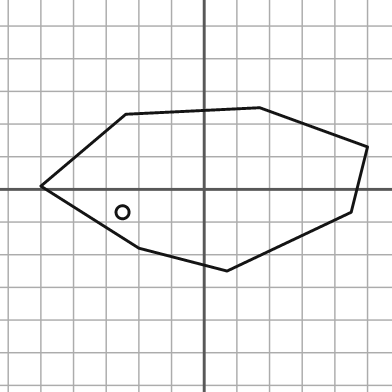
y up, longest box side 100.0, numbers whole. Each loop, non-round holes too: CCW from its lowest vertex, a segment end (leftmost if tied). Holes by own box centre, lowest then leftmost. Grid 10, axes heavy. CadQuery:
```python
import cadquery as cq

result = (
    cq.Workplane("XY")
    .moveTo(7.0, -25.0)
    .lineTo(45.0, -7.0)
    .lineTo(50.0, 13.0)
    .lineTo(17.0, 25.0)
    .lineTo(-24.0, 23.0)
    .lineTo(-50.0, 1.0)
    .lineTo(-20.0, -18.0)
    .close()
    .moveTo(-25.0, -7.0)
    .circle(2.0)
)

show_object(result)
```